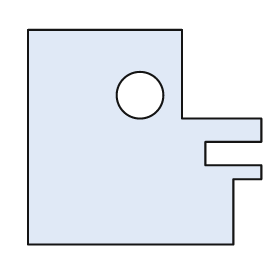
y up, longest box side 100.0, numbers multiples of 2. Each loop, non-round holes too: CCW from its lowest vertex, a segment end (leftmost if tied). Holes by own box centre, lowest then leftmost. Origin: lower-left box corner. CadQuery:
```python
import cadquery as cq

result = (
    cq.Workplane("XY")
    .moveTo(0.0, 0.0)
    .lineTo(88.0, 0.0)
    .lineTo(88.0, 28.0)
    .lineTo(100.0, 28.0)
    .lineTo(100.0, 34.0)
    .lineTo(76.0, 34.0)
    .lineTo(76.0, 44.0)
    .lineTo(100.0, 44.0)
    .lineTo(100.0, 54.0)
    .lineTo(66.0, 54.0)
    .lineTo(66.0, 92.0)
    .lineTo(0.0, 92.0)
    .close()
    .moveTo(48.0, 64.0)
    .circle(10.0)
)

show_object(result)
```